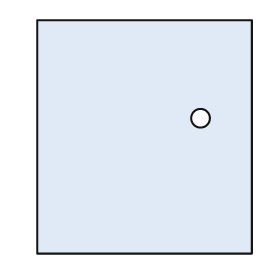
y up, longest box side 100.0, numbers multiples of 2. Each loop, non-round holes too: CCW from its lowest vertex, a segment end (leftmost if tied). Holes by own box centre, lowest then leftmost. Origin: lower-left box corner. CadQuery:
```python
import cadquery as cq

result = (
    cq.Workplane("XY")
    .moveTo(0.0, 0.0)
    .lineTo(92.0, 0.0)
    .lineTo(92.0, 100.0)
    .lineTo(0.0, 100.0)
    .close()
    .moveTo(70.0, 58.0)
    .circle(4.0)
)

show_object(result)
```